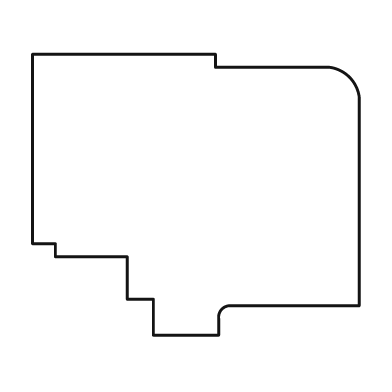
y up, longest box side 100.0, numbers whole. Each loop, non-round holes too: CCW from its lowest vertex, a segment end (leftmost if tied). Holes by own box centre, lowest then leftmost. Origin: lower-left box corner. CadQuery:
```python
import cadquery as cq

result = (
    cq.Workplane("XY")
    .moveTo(37.0, 0.0)
    .lineTo(57.0, 0.0)
    .lineTo(57.0, 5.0)
    .threePointArc((58.0, 8.0), (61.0, 9.0))
    .lineTo(100.0, 9.0)
    .lineTo(100.0, 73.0)
    .threePointArc((97.0, 79.0), (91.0, 82.0))
    .lineTo(56.0, 82.0)
    .lineTo(56.0, 86.0)
    .lineTo(0.0, 86.0)
    .lineTo(0.0, 28.0)
    .lineTo(7.0, 28.0)
    .lineTo(7.0, 24.0)
    .lineTo(29.0, 24.0)
    .lineTo(29.0, 11.0)
    .lineTo(37.0, 11.0)
    .close()
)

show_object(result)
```